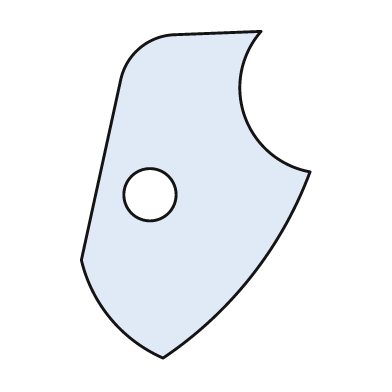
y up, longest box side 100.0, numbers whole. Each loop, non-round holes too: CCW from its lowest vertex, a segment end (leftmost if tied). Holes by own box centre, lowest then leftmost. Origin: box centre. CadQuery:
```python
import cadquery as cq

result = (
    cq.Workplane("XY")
    .moveTo(-10.0, -50.0)
    .threePointArc((17.0, -25.0), (35.0, 7.0))
    .threePointArc((15.0, 24.0), (20.0, 50.0))
    .lineTo(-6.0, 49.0)
    .threePointArc((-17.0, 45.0), (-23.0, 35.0))
    .lineTo(-35.0, -20.0)
    .threePointArc((-26.0, -38.0), (-10.0, -50.0))
    .close()
    .moveTo(-14.0, 0.0)
    .circle(8.0)
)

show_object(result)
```